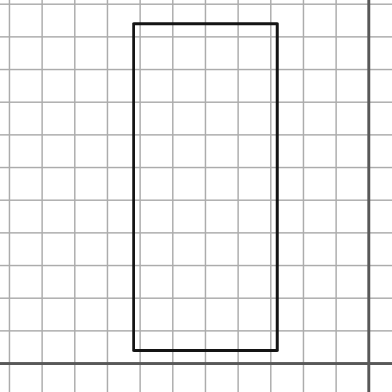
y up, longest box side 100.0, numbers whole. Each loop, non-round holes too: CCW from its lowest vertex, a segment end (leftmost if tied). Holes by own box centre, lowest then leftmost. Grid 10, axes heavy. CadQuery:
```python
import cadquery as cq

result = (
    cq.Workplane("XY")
    .moveTo(-72.0, 4.0)
    .lineTo(-28.0, 4.0)
    .lineTo(-28.0, 104.0)
    .lineTo(-72.0, 104.0)
    .close()
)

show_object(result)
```